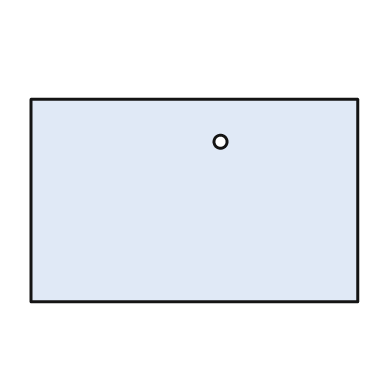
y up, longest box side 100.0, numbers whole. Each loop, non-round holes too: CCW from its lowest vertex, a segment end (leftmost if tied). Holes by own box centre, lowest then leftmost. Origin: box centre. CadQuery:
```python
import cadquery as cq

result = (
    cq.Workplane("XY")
    .moveTo(-50.0, -31.0)
    .lineTo(50.0, -31.0)
    .lineTo(50.0, 31.0)
    .lineTo(-50.0, 31.0)
    .close()
    .moveTo(8.0, 18.0)
    .circle(2.0)
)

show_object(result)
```